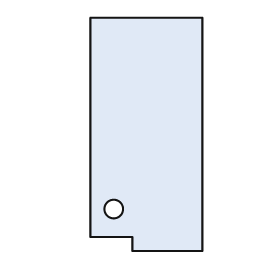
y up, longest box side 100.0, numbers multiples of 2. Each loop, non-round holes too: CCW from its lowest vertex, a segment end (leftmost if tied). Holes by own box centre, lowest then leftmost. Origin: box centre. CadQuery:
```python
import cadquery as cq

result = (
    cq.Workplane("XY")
    .moveTo(-6.0, -50.0)
    .lineTo(24.0, -50.0)
    .lineTo(24.0, 50.0)
    .lineTo(-24.0, 50.0)
    .lineTo(-24.0, -44.0)
    .lineTo(-6.0, -44.0)
    .close()
    .moveTo(-14.0, -32.0)
    .circle(4.0)
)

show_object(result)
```